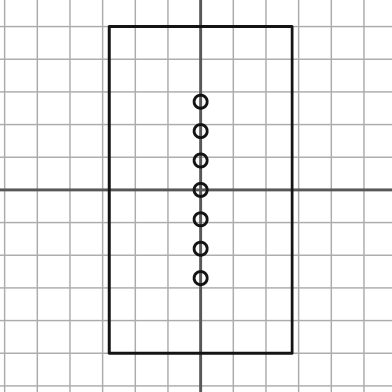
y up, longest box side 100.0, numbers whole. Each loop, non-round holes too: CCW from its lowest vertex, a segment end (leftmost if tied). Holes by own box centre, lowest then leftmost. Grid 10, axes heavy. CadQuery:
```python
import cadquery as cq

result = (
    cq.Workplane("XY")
    .moveTo(-28.0, -50.0)
    .lineTo(28.0, -50.0)
    .lineTo(28.0, 50.0)
    .lineTo(-28.0, 50.0)
    .close()
    .moveTo(0.0, -27.0)
    .circle(2.0)
    .moveTo(0.0, -18.0)
    .circle(2.0)
    .moveTo(0.0, -9.0)
    .circle(2.0)
    .moveTo(0.0, 0.0)
    .circle(2.0)
    .moveTo(0.0, 9.0)
    .circle(2.0)
    .moveTo(0.0, 18.0)
    .circle(2.0)
    .moveTo(0.0, 27.0)
    .circle(2.0)
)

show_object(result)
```